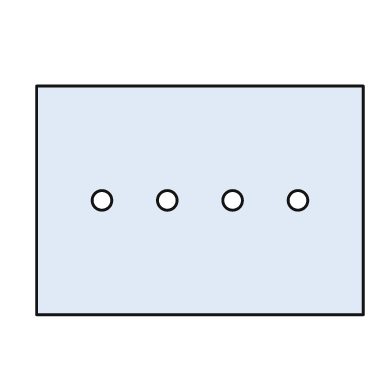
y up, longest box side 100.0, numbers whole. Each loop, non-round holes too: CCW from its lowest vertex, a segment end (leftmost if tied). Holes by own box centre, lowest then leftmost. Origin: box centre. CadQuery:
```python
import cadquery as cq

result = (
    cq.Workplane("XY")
    .moveTo(-50.0, -35.0)
    .lineTo(50.0, -35.0)
    .lineTo(50.0, 35.0)
    .lineTo(-50.0, 35.0)
    .close()
    .moveTo(-30.0, 0.0)
    .circle(3.0)
    .moveTo(-10.0, 0.0)
    .circle(3.0)
    .moveTo(10.0, 0.0)
    .circle(3.0)
    .moveTo(30.0, 0.0)
    .circle(3.0)
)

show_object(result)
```